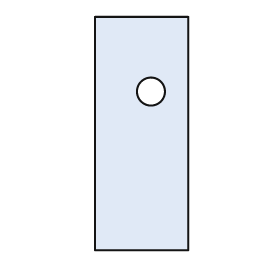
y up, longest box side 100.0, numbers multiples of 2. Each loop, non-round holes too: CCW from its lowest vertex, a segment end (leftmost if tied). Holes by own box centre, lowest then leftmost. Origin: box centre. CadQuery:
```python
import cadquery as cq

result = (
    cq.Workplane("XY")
    .moveTo(-20.0, -50.0)
    .lineTo(20.0, -50.0)
    .lineTo(20.0, 50.0)
    .lineTo(-20.0, 50.0)
    .close()
    .moveTo(4.0, 18.0)
    .circle(6.0)
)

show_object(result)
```